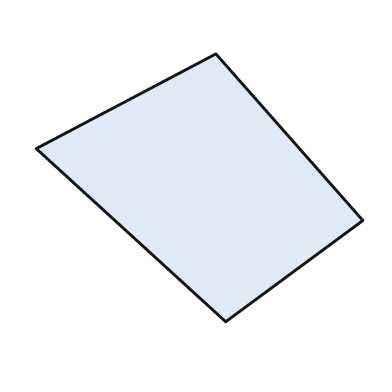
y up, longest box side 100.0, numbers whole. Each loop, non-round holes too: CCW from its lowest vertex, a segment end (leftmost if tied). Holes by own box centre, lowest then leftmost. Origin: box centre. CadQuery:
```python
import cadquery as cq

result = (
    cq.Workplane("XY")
    .moveTo(8.0, -41.0)
    .lineTo(50.0, -10.0)
    .lineTo(5.0, 41.0)
    .lineTo(-50.0, 12.0)
    .close()
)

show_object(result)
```